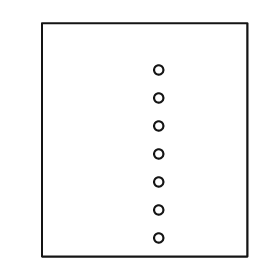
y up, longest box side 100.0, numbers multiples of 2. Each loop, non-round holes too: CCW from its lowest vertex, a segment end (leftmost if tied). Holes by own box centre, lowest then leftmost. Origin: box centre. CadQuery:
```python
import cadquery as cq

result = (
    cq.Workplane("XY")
    .moveTo(-44.0, -50.0)
    .lineTo(44.0, -50.0)
    .lineTo(44.0, 50.0)
    .lineTo(-44.0, 50.0)
    .close()
    .moveTo(6.0, -42.0)
    .circle(2.0)
    .moveTo(6.0, -30.0)
    .circle(2.0)
    .moveTo(6.0, -18.0)
    .circle(2.0)
    .moveTo(6.0, -6.0)
    .circle(2.0)
    .moveTo(6.0, 6.0)
    .circle(2.0)
    .moveTo(6.0, 18.0)
    .circle(2.0)
    .moveTo(6.0, 30.0)
    .circle(2.0)
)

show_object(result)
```